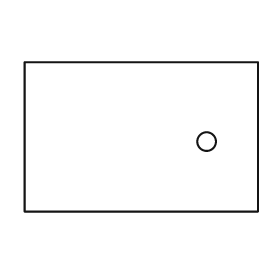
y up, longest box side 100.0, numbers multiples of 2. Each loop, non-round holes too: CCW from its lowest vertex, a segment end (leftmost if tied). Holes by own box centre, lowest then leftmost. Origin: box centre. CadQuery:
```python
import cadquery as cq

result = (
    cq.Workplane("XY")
    .moveTo(-50.0, -32.0)
    .lineTo(50.0, -32.0)
    .lineTo(50.0, 32.0)
    .lineTo(-50.0, 32.0)
    .close()
    .moveTo(28.0, -2.0)
    .circle(4.0)
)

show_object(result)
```